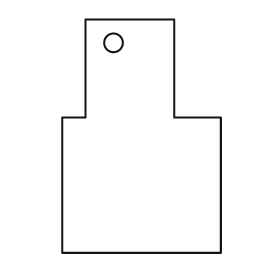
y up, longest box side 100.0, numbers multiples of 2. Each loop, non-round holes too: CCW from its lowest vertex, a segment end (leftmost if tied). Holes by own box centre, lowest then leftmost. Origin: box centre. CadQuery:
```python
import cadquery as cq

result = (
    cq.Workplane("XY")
    .moveTo(-34.0, -50.0)
    .lineTo(34.0, -50.0)
    .lineTo(34.0, 8.0)
    .lineTo(14.0, 8.0)
    .lineTo(14.0, 50.0)
    .lineTo(-24.0, 50.0)
    .lineTo(-24.0, 8.0)
    .lineTo(-34.0, 8.0)
    .close()
    .moveTo(-12.0, 40.0)
    .circle(4.0)
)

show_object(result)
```